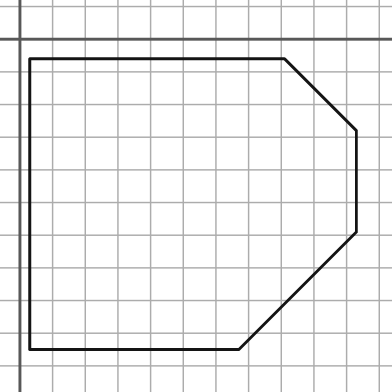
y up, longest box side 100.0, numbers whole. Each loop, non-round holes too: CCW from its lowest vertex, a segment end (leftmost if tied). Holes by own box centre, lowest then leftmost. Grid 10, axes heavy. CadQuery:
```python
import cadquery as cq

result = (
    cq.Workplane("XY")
    .moveTo(3.0, -95.0)
    .lineTo(67.0, -95.0)
    .lineTo(103.0, -59.0)
    .lineTo(103.0, -28.0)
    .lineTo(81.0, -6.0)
    .lineTo(3.0, -6.0)
    .close()
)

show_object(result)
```